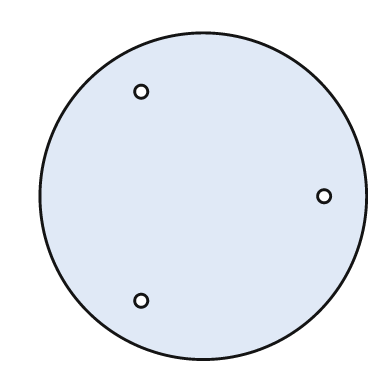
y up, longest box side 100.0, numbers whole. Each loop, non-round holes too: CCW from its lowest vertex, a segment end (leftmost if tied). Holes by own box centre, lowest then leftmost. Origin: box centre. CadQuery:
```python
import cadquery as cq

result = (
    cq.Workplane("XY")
    .moveTo(0.0, 0.0)
    .circle(50.0)
    .moveTo(-19.0, -32.0)
    .circle(2.0)
    .moveTo(37.0, 0.0)
    .circle(2.0)
    .moveTo(-19.0, 32.0)
    .circle(2.0)
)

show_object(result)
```